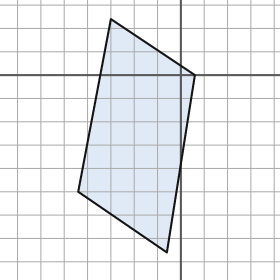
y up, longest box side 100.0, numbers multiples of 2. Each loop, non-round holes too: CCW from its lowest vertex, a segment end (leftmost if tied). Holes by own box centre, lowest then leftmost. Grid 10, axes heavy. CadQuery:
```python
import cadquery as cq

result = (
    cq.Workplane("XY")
    .moveTo(-6.0, -76.0)
    .lineTo(6.0, 0.0)
    .lineTo(-30.0, 24.0)
    .lineTo(-44.0, -50.0)
    .close()
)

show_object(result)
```